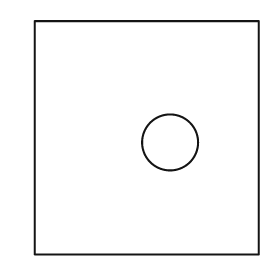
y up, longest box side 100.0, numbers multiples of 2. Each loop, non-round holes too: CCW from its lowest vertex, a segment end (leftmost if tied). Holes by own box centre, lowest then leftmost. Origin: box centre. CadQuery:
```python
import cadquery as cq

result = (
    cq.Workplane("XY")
    .moveTo(-48.0, -50.0)
    .lineTo(48.0, -50.0)
    .lineTo(48.0, 50.0)
    .lineTo(-48.0, 50.0)
    .close()
    .moveTo(10.0, -2.0)
    .circle(12.0)
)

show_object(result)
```